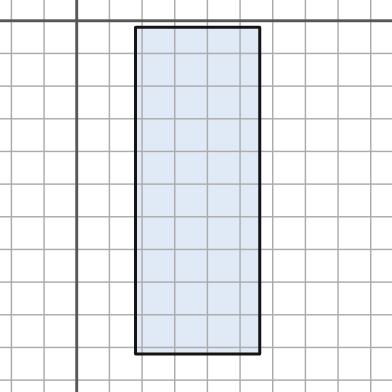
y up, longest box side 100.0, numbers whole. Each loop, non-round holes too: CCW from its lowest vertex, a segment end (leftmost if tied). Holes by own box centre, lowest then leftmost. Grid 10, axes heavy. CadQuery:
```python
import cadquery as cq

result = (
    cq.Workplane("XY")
    .moveTo(18.0, -102.0)
    .lineTo(56.0, -102.0)
    .lineTo(56.0, -2.0)
    .lineTo(18.0, -2.0)
    .close()
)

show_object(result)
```